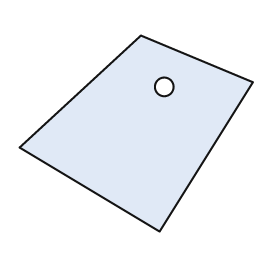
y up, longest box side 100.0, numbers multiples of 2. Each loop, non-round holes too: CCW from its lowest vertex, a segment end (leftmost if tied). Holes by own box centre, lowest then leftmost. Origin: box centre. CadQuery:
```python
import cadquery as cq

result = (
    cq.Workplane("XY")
    .moveTo(10.0, -42.0)
    .lineTo(50.0, 22.0)
    .lineTo(2.0, 42.0)
    .lineTo(-50.0, -6.0)
    .close()
    .moveTo(12.0, 20.0)
    .circle(4.0)
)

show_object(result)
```